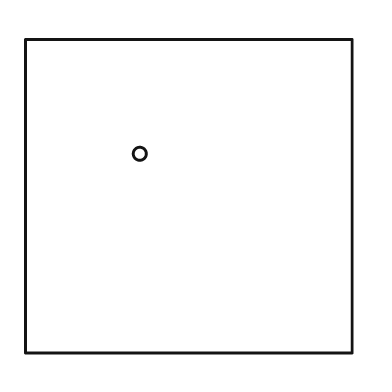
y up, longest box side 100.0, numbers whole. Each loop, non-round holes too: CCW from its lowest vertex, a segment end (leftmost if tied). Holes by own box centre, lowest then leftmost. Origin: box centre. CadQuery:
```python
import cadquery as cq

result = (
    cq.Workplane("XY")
    .moveTo(-50.0, -48.0)
    .lineTo(50.0, -48.0)
    .lineTo(50.0, 48.0)
    .lineTo(-50.0, 48.0)
    .close()
    .moveTo(-15.0, 13.0)
    .circle(2.0)
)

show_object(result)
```